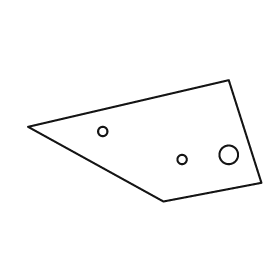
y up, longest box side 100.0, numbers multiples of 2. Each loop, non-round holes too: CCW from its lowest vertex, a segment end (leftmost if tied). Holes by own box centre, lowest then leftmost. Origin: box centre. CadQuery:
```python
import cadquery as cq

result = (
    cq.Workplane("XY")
    .moveTo(8.0, -26.0)
    .lineTo(50.0, -18.0)
    .lineTo(36.0, 26.0)
    .lineTo(-50.0, 6.0)
    .close()
    .moveTo(16.0, -8.0)
    .circle(2.0)
    .moveTo(36.0, -6.0)
    .circle(4.0)
    .moveTo(-18.0, 4.0)
    .circle(2.0)
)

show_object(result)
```